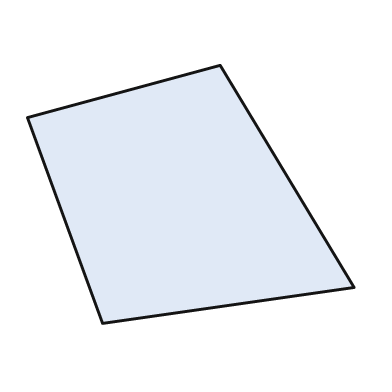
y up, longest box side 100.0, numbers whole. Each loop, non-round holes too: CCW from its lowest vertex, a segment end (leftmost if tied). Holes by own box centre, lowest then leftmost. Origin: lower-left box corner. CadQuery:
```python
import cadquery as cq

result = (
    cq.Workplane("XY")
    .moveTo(23.0, 0.0)
    .lineTo(100.0, 11.0)
    .lineTo(59.0, 79.0)
    .lineTo(0.0, 63.0)
    .close()
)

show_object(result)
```